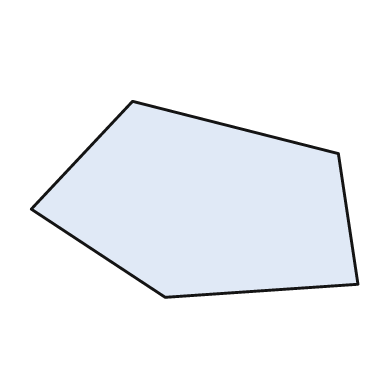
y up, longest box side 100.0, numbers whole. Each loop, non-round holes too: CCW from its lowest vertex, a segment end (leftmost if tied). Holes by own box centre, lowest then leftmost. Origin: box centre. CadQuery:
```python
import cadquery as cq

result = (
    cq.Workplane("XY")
    .moveTo(-9.0, -30.0)
    .lineTo(50.0, -26.0)
    .lineTo(44.0, 14.0)
    .lineTo(-19.0, 30.0)
    .lineTo(-50.0, -3.0)
    .close()
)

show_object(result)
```